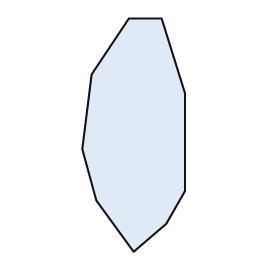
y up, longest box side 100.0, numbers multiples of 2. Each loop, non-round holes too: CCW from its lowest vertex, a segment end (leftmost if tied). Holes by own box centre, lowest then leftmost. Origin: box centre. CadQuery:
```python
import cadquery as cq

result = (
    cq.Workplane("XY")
    .moveTo(0.0, -50.0)
    .lineTo(14.0, -38.0)
    .lineTo(22.0, -24.0)
    .lineTo(22.0, 18.0)
    .lineTo(12.0, 50.0)
    .lineTo(-2.0, 50.0)
    .lineTo(-18.0, 26.0)
    .lineTo(-22.0, -6.0)
    .lineTo(-16.0, -28.0)
    .close()
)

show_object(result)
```